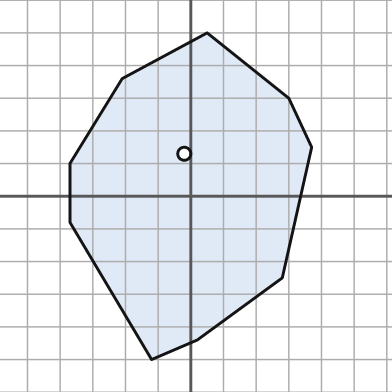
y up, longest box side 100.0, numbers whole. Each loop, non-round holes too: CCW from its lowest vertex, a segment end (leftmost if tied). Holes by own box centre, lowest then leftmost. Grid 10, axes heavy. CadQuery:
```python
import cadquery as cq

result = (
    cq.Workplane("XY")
    .moveTo(-12.0, -50.0)
    .lineTo(2.0, -44.0)
    .lineTo(28.0, -25.0)
    .lineTo(37.0, 15.0)
    .lineTo(30.0, 30.0)
    .lineTo(5.0, 50.0)
    .lineTo(-21.0, 36.0)
    .lineTo(-37.0, 10.0)
    .lineTo(-37.0, -8.0)
    .close()
    .moveTo(-2.0, 13.0)
    .circle(2.0)
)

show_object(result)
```